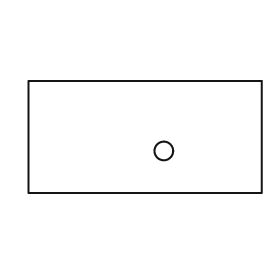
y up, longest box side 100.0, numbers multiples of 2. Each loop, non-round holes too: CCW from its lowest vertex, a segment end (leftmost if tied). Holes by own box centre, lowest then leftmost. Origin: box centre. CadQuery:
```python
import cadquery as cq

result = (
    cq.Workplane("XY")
    .moveTo(-50.0, -24.0)
    .lineTo(50.0, -24.0)
    .lineTo(50.0, 24.0)
    .lineTo(-50.0, 24.0)
    .close()
    .moveTo(8.0, -6.0)
    .circle(4.0)
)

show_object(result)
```